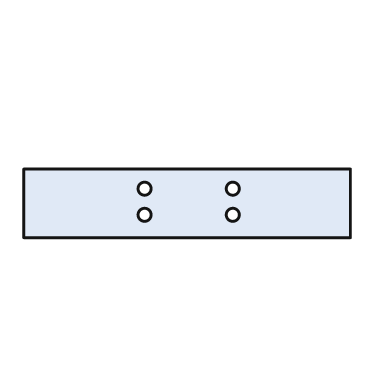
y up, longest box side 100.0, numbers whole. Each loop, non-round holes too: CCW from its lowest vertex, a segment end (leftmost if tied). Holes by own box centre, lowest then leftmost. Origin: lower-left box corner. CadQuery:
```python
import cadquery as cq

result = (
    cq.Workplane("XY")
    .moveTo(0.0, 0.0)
    .lineTo(100.0, 0.0)
    .lineTo(100.0, 21.0)
    .lineTo(0.0, 21.0)
    .close()
    .moveTo(37.0, 7.0)
    .circle(2.0)
    .moveTo(64.0, 7.0)
    .circle(2.0)
    .moveTo(37.0, 15.0)
    .circle(2.0)
    .moveTo(64.0, 15.0)
    .circle(2.0)
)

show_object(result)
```